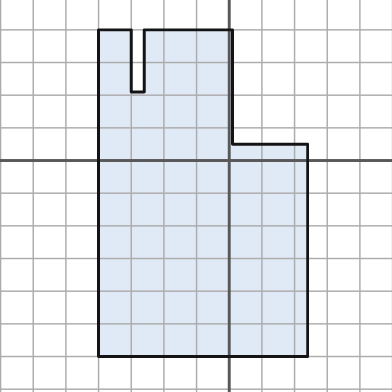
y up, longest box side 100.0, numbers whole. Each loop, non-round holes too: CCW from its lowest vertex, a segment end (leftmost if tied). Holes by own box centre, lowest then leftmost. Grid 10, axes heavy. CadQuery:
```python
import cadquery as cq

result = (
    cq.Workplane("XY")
    .moveTo(-40.0, -60.0)
    .lineTo(24.0, -60.0)
    .lineTo(24.0, 5.0)
    .lineTo(1.0, 5.0)
    .lineTo(1.0, 40.0)
    .lineTo(-26.0, 40.0)
    .lineTo(-26.0, 21.0)
    .lineTo(-30.0, 21.0)
    .lineTo(-30.0, 40.0)
    .lineTo(-40.0, 40.0)
    .close()
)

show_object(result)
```